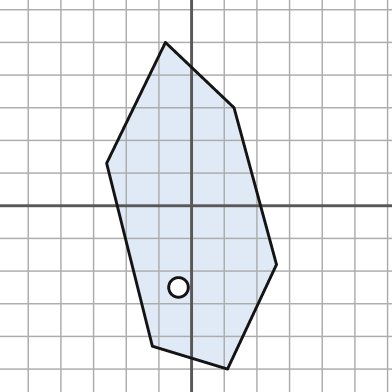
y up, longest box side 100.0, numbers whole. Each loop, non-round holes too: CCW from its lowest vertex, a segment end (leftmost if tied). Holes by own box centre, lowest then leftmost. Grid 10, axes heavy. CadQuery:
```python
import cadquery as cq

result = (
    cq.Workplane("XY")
    .moveTo(11.0, -50.0)
    .lineTo(26.0, -18.0)
    .lineTo(13.0, 30.0)
    .lineTo(-8.0, 50.0)
    .lineTo(-26.0, 13.0)
    .lineTo(-12.0, -43.0)
    .close()
    .moveTo(-4.0, -25.0)
    .circle(3.0)
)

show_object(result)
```